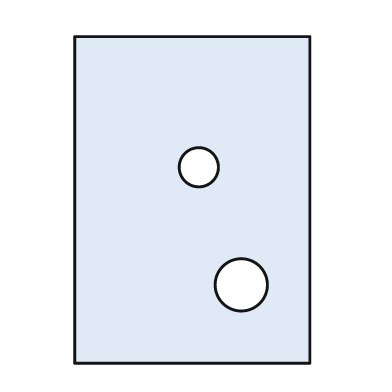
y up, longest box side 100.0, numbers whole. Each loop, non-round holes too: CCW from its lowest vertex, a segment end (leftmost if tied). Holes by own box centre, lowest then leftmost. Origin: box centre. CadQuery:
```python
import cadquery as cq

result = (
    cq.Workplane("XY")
    .moveTo(-36.0, -50.0)
    .lineTo(36.0, -50.0)
    .lineTo(36.0, 50.0)
    .lineTo(-36.0, 50.0)
    .close()
    .moveTo(15.0, -26.0)
    .circle(8.0)
    .moveTo(2.0, 10.0)
    .circle(6.0)
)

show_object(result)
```